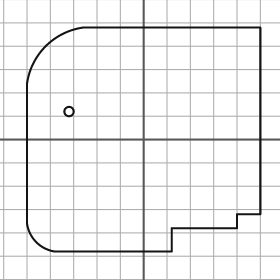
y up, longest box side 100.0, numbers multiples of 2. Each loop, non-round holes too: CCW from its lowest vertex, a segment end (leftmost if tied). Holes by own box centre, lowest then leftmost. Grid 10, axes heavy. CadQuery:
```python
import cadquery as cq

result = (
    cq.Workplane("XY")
    .moveTo(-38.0, -48.0)
    .lineTo(12.0, -48.0)
    .lineTo(12.0, -38.0)
    .lineTo(40.0, -38.0)
    .lineTo(40.0, -32.0)
    .lineTo(50.0, -32.0)
    .lineTo(50.0, 48.0)
    .lineTo(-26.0, 48.0)
    .threePointArc((-42.0, 40.0), (-50.0, 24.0))
    .lineTo(-50.0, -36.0)
    .threePointArc((-46.0, -44.0), (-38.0, -48.0))
    .close()
    .moveTo(-32.0, 12.0)
    .circle(2.0)
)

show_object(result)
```